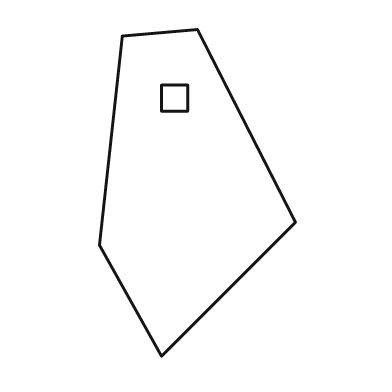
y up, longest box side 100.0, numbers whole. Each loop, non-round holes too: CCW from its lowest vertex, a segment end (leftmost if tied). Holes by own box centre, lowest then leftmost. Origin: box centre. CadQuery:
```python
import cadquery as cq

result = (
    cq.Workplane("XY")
    .moveTo(-11.0, -50.0)
    .lineTo(30.0, -9.0)
    .lineTo(0.0, 50.0)
    .lineTo(-23.0, 48.0)
    .lineTo(-30.0, -16.0)
    .close()
    .moveTo(-11.0, 25.0)
    .lineTo(-3.0, 25.0)
    .lineTo(-3.0, 33.0)
    .lineTo(-11.0, 33.0)
    .close()
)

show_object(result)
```